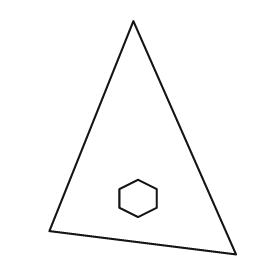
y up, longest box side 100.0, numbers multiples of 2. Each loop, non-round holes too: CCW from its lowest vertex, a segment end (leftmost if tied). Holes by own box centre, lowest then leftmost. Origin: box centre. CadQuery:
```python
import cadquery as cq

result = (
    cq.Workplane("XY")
    .moveTo(40.0, -50.0)
    .lineTo(-4.0, 50.0)
    .lineTo(-40.0, -40.0)
    .close()
    .moveTo(-2.0, -34.0)
    .lineTo(6.0, -30.0)
    .lineTo(6.0, -22.0)
    .lineTo(-2.0, -18.0)
    .lineTo(-10.0, -22.0)
    .lineTo(-10.0, -30.0)
    .close()
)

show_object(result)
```